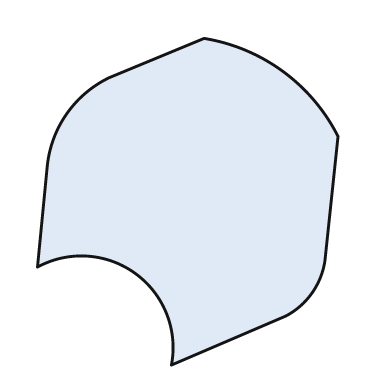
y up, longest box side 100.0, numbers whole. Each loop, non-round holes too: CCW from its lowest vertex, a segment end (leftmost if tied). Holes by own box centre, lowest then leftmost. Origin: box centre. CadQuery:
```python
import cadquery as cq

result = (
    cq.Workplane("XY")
    .moveTo(-5.0, -50.0)
    .lineTo(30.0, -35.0)
    .threePointArc((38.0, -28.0), (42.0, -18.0))
    .lineTo(46.0, 20.0)
    .threePointArc((29.0, 40.0), (5.0, 50.0))
    .lineTo(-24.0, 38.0)
    .threePointArc((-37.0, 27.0), (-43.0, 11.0))
    .lineTo(-46.0, -20.0)
    .threePointArc((-16.0, -22.0), (-5.0, -50.0))
    .close()
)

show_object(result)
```